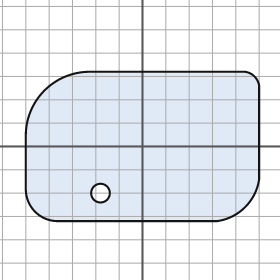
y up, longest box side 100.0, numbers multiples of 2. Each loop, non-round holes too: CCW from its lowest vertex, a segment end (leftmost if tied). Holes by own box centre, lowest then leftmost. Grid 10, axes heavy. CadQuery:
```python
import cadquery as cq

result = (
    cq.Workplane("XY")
    .moveTo(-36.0, -32.0)
    .lineTo(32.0, -32.0)
    .threePointArc((44.0, -26.0), (50.0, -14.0))
    .lineTo(50.0, 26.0)
    .threePointArc((48.0, 30.0), (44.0, 32.0))
    .lineTo(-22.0, 32.0)
    .threePointArc((-42.0, 24.0), (-50.0, 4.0))
    .lineTo(-50.0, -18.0)
    .threePointArc((-46.0, -28.0), (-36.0, -32.0))
    .close()
    .moveTo(-18.0, -20.0)
    .circle(4.0)
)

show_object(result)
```